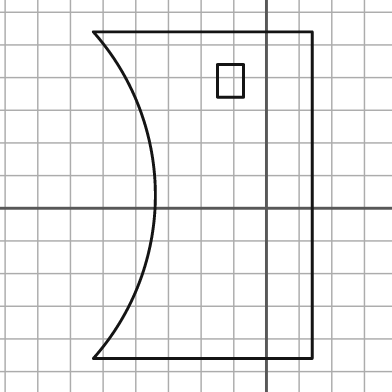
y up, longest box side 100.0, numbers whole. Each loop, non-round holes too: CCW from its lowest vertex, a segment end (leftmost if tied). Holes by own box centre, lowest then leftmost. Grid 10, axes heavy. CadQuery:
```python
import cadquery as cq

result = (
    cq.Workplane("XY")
    .moveTo(-53.0, -46.0)
    .lineTo(14.0, -46.0)
    .lineTo(14.0, 54.0)
    .lineTo(-53.0, 54.0)
    .threePointArc((-34.0, 4.0), (-53.0, -46.0))
    .close()
    .moveTo(-15.0, 34.0)
    .lineTo(-7.0, 34.0)
    .lineTo(-7.0, 44.0)
    .lineTo(-15.0, 44.0)
    .close()
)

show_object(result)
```